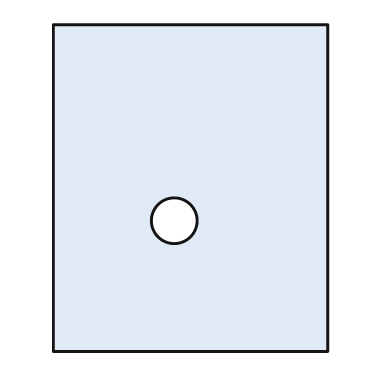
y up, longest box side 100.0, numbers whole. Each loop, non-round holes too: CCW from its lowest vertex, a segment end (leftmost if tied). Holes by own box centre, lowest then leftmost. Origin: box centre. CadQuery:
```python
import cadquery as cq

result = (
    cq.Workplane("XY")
    .moveTo(-42.0, -50.0)
    .lineTo(42.0, -50.0)
    .lineTo(42.0, 50.0)
    .lineTo(-42.0, 50.0)
    .close()
    .moveTo(-5.0, -10.0)
    .circle(7.0)
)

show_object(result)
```